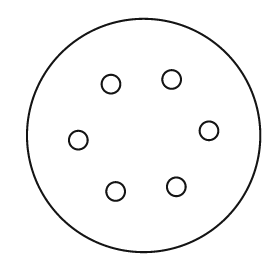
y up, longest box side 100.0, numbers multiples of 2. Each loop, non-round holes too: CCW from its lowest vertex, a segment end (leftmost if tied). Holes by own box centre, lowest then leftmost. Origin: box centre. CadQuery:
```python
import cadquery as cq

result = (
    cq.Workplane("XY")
    .moveTo(0.0, 0.0)
    .circle(50.0)
    .moveTo(-12.0, -24.0)
    .circle(4.0)
    .moveTo(14.0, -22.0)
    .circle(4.0)
    .moveTo(-28.0, -2.0)
    .circle(4.0)
    .moveTo(28.0, 2.0)
    .circle(4.0)
    .moveTo(-14.0, 22.0)
    .circle(4.0)
    .moveTo(12.0, 24.0)
    .circle(4.0)
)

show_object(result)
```